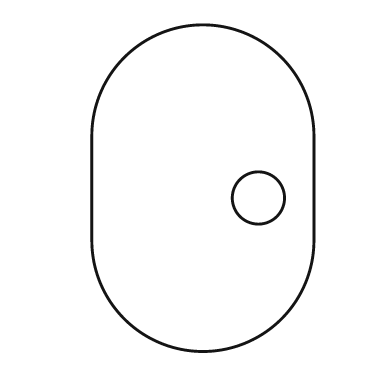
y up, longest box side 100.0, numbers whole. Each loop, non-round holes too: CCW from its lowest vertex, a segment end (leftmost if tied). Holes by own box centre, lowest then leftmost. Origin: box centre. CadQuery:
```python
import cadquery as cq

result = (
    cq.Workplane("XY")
    .moveTo(-34.0, -16.0)
    .threePointArc((0.0, -50.0), (34.0, -16.0))
    .lineTo(34.0, 16.0)
    .threePointArc((0.0, 50.0), (-34.0, 16.0))
    .close()
    .moveTo(17.0, -3.0)
    .circle(8.0)
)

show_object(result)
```